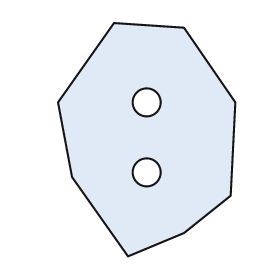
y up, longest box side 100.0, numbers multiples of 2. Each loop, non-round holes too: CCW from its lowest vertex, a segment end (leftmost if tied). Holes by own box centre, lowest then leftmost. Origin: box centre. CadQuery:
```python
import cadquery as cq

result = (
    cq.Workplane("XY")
    .moveTo(-8.0, -50.0)
    .lineTo(16.0, -40.0)
    .lineTo(36.0, -24.0)
    .lineTo(38.0, 16.0)
    .lineTo(16.0, 48.0)
    .lineTo(-14.0, 50.0)
    .lineTo(-38.0, 16.0)
    .lineTo(-32.0, -16.0)
    .close()
    .moveTo(0.0, -14.0)
    .circle(6.0)
    .moveTo(0.0, 16.0)
    .circle(6.0)
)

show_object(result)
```